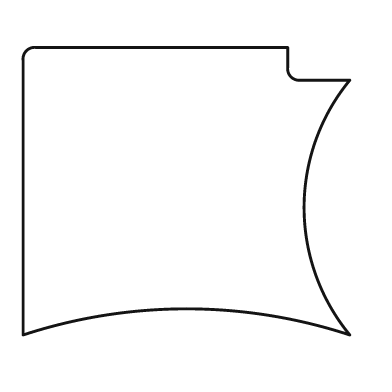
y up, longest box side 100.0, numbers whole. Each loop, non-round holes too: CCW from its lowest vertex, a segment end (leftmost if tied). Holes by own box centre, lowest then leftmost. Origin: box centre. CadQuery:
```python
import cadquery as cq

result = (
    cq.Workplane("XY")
    .moveTo(-50.0, -44.0)
    .threePointArc((0.0, -36.0), (50.0, -44.0))
    .threePointArc((36.0, -5.0), (50.0, 34.0))
    .lineTo(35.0, 34.0)
    .threePointArc((32.0, 35.0), (31.0, 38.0))
    .lineTo(31.0, 44.0)
    .lineTo(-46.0, 44.0)
    .threePointArc((-49.0, 43.0), (-50.0, 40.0))
    .close()
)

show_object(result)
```